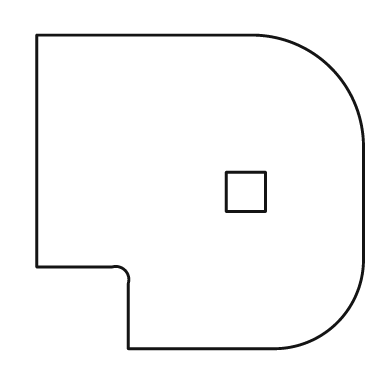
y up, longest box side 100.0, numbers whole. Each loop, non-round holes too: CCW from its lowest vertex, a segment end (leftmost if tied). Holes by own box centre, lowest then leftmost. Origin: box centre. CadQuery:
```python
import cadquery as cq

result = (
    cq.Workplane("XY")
    .moveTo(-22.0, -48.0)
    .lineTo(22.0, -48.0)
    .threePointArc((42.0, -40.0), (50.0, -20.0))
    .lineTo(50.0, 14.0)
    .threePointArc((40.0, 38.0), (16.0, 48.0))
    .lineTo(-50.0, 48.0)
    .lineTo(-50.0, -23.0)
    .lineTo(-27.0, -23.0)
    .threePointArc((-23.0, -24.0), (-22.0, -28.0))
    .close()
    .moveTo(8.0, -6.0)
    .lineTo(20.0, -6.0)
    .lineTo(20.0, 6.0)
    .lineTo(8.0, 6.0)
    .close()
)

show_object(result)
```